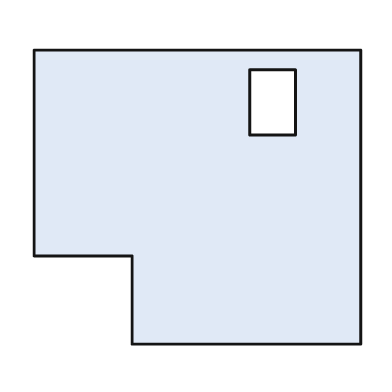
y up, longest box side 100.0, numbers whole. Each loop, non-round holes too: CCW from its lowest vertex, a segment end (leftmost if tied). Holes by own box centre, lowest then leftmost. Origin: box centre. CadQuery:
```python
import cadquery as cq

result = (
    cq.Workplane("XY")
    .moveTo(-20.0, -45.0)
    .lineTo(50.0, -45.0)
    .lineTo(50.0, 45.0)
    .lineTo(-50.0, 45.0)
    .lineTo(-50.0, -18.0)
    .lineTo(-20.0, -18.0)
    .close()
    .moveTo(16.0, 19.0)
    .lineTo(30.0, 19.0)
    .lineTo(30.0, 39.0)
    .lineTo(16.0, 39.0)
    .close()
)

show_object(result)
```